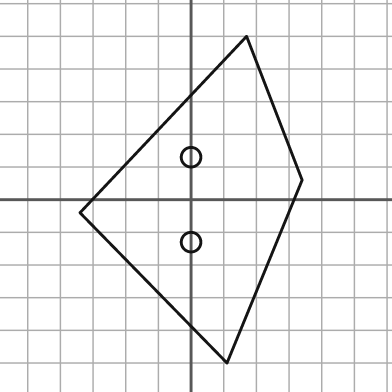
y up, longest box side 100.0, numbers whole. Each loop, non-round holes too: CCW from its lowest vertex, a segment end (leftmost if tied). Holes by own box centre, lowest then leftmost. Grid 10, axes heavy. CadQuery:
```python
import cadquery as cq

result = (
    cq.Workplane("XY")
    .moveTo(11.0, -50.0)
    .lineTo(34.0, 6.0)
    .lineTo(17.0, 50.0)
    .lineTo(-34.0, -4.0)
    .close()
    .moveTo(0.0, -13.0)
    .circle(3.0)
    .moveTo(0.0, 13.0)
    .circle(3.0)
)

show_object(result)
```